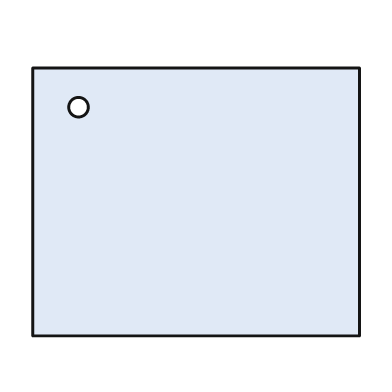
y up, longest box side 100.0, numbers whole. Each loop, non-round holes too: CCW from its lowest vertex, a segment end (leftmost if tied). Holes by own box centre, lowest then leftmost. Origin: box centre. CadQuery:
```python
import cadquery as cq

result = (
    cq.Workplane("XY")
    .moveTo(-50.0, -41.0)
    .lineTo(50.0, -41.0)
    .lineTo(50.0, 41.0)
    .lineTo(-50.0, 41.0)
    .close()
    .moveTo(-36.0, 29.0)
    .circle(3.0)
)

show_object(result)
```